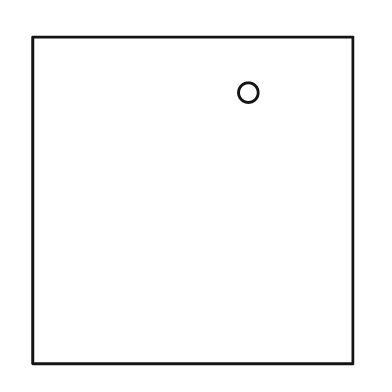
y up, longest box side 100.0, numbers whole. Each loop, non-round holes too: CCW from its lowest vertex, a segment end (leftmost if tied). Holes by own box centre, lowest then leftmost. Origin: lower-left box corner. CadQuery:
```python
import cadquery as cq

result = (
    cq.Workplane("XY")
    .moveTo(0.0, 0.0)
    .lineTo(98.0, 0.0)
    .lineTo(98.0, 100.0)
    .lineTo(0.0, 100.0)
    .close()
    .moveTo(66.0, 83.0)
    .circle(3.0)
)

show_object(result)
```